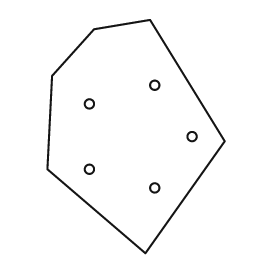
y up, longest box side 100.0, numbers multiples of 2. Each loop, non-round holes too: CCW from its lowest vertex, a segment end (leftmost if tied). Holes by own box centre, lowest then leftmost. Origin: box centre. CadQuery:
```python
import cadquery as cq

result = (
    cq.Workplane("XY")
    .moveTo(4.0, -50.0)
    .lineTo(38.0, -2.0)
    .lineTo(6.0, 50.0)
    .lineTo(-18.0, 46.0)
    .lineTo(-36.0, 26.0)
    .lineTo(-38.0, -14.0)
    .close()
    .moveTo(8.0, -22.0)
    .circle(2.0)
    .moveTo(-20.0, -14.0)
    .circle(2.0)
    .moveTo(24.0, 0.0)
    .circle(2.0)
    .moveTo(-20.0, 14.0)
    .circle(2.0)
    .moveTo(8.0, 22.0)
    .circle(2.0)
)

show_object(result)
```